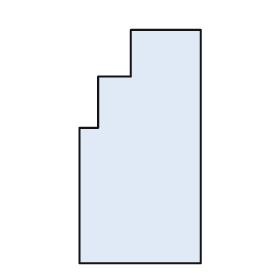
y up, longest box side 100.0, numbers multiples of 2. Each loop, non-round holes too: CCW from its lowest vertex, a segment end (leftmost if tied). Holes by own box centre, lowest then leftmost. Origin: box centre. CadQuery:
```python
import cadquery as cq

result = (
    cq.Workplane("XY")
    .moveTo(-26.0, -50.0)
    .lineTo(26.0, -50.0)
    .lineTo(26.0, 50.0)
    .lineTo(-4.0, 50.0)
    .lineTo(-4.0, 30.0)
    .lineTo(-18.0, 30.0)
    .lineTo(-18.0, 8.0)
    .lineTo(-26.0, 8.0)
    .close()
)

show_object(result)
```